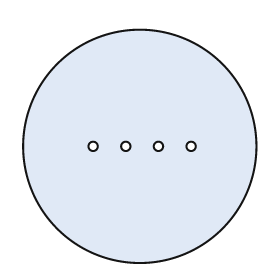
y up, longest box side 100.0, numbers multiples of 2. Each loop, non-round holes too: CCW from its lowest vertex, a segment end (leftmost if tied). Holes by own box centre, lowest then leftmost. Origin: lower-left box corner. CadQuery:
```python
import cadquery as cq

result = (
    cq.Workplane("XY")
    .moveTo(50.0, 50.0)
    .circle(50.0)
    .moveTo(30.0, 50.0)
    .circle(2.0)
    .moveTo(44.0, 50.0)
    .circle(2.0)
    .moveTo(58.0, 50.0)
    .circle(2.0)
    .moveTo(72.0, 50.0)
    .circle(2.0)
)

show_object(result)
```